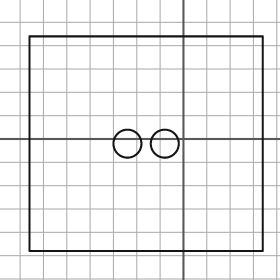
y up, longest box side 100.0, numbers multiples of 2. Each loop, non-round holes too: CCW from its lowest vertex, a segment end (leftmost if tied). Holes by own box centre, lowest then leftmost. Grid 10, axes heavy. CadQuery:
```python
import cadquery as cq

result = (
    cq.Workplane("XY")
    .moveTo(-66.0, -48.0)
    .lineTo(34.0, -48.0)
    .lineTo(34.0, 44.0)
    .lineTo(-66.0, 44.0)
    .close()
    .moveTo(-24.0, -2.0)
    .circle(6.0)
    .moveTo(-8.0, -2.0)
    .circle(6.0)
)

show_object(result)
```